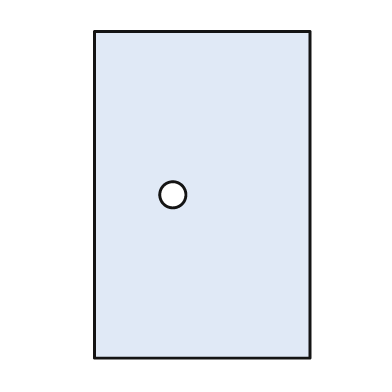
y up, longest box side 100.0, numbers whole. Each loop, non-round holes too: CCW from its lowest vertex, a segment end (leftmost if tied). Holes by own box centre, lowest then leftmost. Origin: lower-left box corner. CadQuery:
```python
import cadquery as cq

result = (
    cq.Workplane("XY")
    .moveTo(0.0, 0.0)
    .lineTo(66.0, 0.0)
    .lineTo(66.0, 100.0)
    .lineTo(0.0, 100.0)
    .close()
    .moveTo(24.0, 50.0)
    .circle(4.0)
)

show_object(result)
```